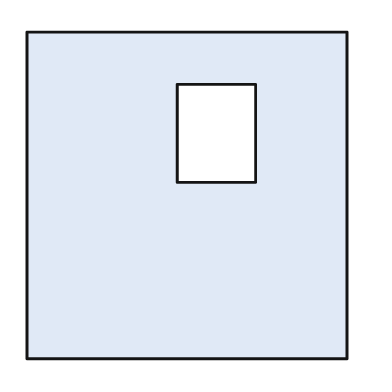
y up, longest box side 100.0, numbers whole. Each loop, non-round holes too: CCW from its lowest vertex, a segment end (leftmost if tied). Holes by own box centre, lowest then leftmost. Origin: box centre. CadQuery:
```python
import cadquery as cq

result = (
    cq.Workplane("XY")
    .moveTo(-49.0, -50.0)
    .lineTo(49.0, -50.0)
    .lineTo(49.0, 50.0)
    .lineTo(-49.0, 50.0)
    .close()
    .moveTo(-3.0, 4.0)
    .lineTo(21.0, 4.0)
    .lineTo(21.0, 34.0)
    .lineTo(-3.0, 34.0)
    .close()
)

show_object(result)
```